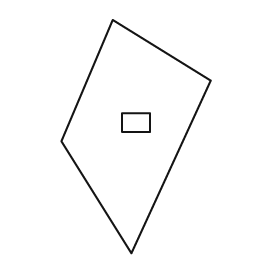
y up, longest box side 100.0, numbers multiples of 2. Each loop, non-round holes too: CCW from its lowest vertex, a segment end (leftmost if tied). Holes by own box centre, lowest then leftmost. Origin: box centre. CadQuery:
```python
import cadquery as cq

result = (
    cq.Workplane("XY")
    .moveTo(-2.0, -50.0)
    .lineTo(32.0, 24.0)
    .lineTo(-10.0, 50.0)
    .lineTo(-32.0, -2.0)
    .close()
    .moveTo(-6.0, 2.0)
    .lineTo(6.0, 2.0)
    .lineTo(6.0, 10.0)
    .lineTo(-6.0, 10.0)
    .close()
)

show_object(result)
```